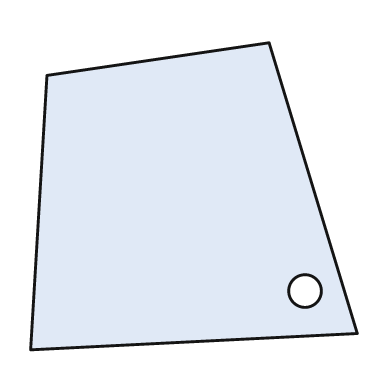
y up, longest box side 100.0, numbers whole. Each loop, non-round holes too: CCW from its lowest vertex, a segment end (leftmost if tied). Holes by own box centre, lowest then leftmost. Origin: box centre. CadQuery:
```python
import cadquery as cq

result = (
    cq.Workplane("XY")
    .moveTo(-50.0, -47.0)
    .lineTo(50.0, -42.0)
    .lineTo(23.0, 47.0)
    .lineTo(-45.0, 37.0)
    .close()
    .moveTo(34.0, -29.0)
    .circle(5.0)
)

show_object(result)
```